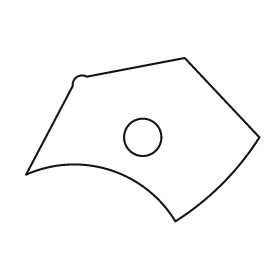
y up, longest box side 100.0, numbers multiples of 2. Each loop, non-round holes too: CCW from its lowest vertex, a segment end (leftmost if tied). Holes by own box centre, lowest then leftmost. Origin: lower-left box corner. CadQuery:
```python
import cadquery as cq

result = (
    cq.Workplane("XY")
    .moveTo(64.0, 0.0)
    .threePointArc((84.0, 16.0), (100.0, 36.0))
    .lineTo(68.0, 70.0)
    .lineTo(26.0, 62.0)
    .threePointArc((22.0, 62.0), (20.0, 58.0))
    .lineTo(0.0, 20.0)
    .threePointArc((36.0, 22.0), (64.0, 0.0))
    .close()
    .moveTo(50.0, 36.0)
    .circle(8.0)
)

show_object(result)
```